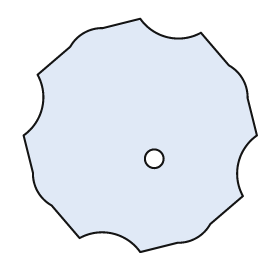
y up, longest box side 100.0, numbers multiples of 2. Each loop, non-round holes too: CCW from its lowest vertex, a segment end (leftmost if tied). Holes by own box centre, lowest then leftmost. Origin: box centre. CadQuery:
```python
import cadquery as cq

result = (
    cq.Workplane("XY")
    .moveTo(0.0, -50.0)
    .lineTo(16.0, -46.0)
    .threePointArc((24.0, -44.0), (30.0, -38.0))
    .lineTo(44.0, -26.0)
    .threePointArc((42.0, -12.0), (50.0, 0.0))
    .lineTo(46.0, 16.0)
    .threePointArc((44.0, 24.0), (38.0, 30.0))
    .lineTo(26.0, 44.0)
    .threePointArc((12.0, 42.0), (0.0, 50.0))
    .lineTo(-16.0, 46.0)
    .threePointArc((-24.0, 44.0), (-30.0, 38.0))
    .lineTo(-44.0, 26.0)
    .threePointArc((-42.0, 12.0), (-50.0, 0.0))
    .lineTo(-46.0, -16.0)
    .threePointArc((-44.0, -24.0), (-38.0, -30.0))
    .lineTo(-26.0, -44.0)
    .threePointArc((-12.0, -42.0), (0.0, -50.0))
    .close()
    .moveTo(6.0, -10.0)
    .circle(4.0)
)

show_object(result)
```